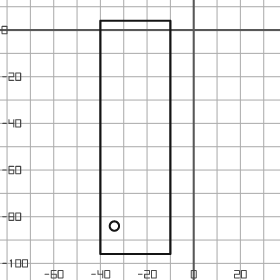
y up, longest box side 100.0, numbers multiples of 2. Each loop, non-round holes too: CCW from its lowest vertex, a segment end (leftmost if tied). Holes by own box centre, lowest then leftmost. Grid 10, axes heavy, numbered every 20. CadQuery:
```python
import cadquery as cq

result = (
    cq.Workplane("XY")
    .moveTo(-40.0, -96.0)
    .lineTo(-10.0, -96.0)
    .lineTo(-10.0, 4.0)
    .lineTo(-40.0, 4.0)
    .close()
    .moveTo(-34.0, -84.0)
    .circle(2.0)
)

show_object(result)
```